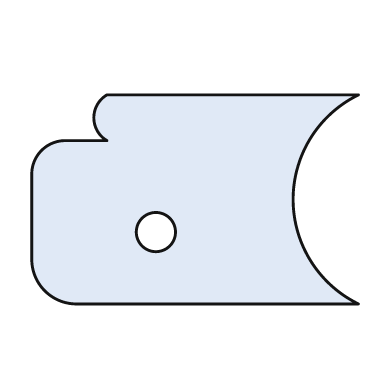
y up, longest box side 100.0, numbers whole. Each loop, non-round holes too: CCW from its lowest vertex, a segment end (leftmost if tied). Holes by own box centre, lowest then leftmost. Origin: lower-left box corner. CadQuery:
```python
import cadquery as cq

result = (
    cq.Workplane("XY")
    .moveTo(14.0, 0.0)
    .lineTo(100.0, 0.0)
    .threePointArc((80.0, 32.0), (100.0, 64.0))
    .lineTo(23.0, 64.0)
    .threePointArc((19.0, 57.0), (23.0, 50.0))
    .lineTo(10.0, 50.0)
    .threePointArc((3.0, 47.0), (0.0, 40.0))
    .lineTo(0.0, 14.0)
    .threePointArc((4.0, 4.0), (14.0, 0.0))
    .close()
    .moveTo(38.0, 22.0)
    .circle(6.0)
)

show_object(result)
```